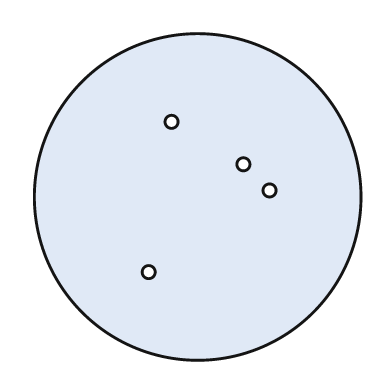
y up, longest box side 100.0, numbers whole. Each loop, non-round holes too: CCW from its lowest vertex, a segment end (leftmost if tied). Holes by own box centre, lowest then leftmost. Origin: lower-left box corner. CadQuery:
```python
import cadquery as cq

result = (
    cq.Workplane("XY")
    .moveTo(50.0, 50.0)
    .circle(50.0)
    .moveTo(35.0, 27.0)
    .circle(2.0)
    .moveTo(72.0, 52.0)
    .circle(2.0)
    .moveTo(64.0, 60.0)
    .circle(2.0)
    .moveTo(42.0, 73.0)
    .circle(2.0)
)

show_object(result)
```